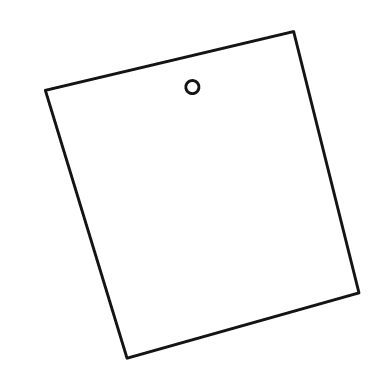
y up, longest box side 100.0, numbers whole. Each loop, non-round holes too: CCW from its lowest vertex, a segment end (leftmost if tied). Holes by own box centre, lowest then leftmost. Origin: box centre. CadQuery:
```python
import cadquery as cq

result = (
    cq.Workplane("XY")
    .moveTo(-23.0, -50.0)
    .lineTo(48.0, -30.0)
    .lineTo(28.0, 50.0)
    .lineTo(-48.0, 32.0)
    .close()
    .moveTo(-3.0, 33.0)
    .circle(2.0)
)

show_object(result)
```